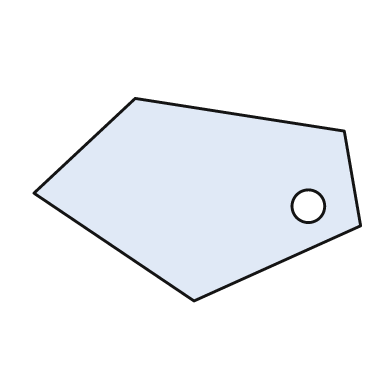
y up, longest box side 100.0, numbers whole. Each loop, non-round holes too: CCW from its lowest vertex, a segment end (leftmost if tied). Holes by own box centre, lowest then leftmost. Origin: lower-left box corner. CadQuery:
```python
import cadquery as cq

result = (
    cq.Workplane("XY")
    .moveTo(49.0, 0.0)
    .lineTo(100.0, 23.0)
    .lineTo(95.0, 52.0)
    .lineTo(31.0, 62.0)
    .lineTo(0.0, 33.0)
    .close()
    .moveTo(84.0, 29.0)
    .circle(5.0)
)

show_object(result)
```